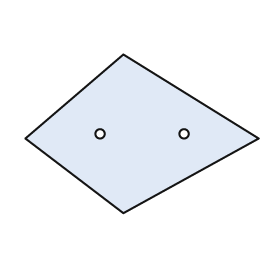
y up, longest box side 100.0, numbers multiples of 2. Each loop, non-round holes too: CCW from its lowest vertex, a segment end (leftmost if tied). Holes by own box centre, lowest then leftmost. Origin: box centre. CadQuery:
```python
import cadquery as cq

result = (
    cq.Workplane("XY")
    .moveTo(-8.0, -34.0)
    .lineTo(50.0, -2.0)
    .lineTo(-8.0, 34.0)
    .lineTo(-50.0, -2.0)
    .close()
    .moveTo(-18.0, 0.0)
    .circle(2.0)
    .moveTo(18.0, 0.0)
    .circle(2.0)
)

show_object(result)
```